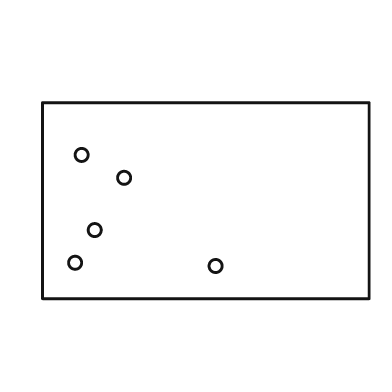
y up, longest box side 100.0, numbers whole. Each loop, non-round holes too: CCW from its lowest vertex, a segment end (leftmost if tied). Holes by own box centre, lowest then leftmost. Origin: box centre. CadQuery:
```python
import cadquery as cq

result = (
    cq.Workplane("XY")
    .moveTo(-50.0, -30.0)
    .lineTo(50.0, -30.0)
    .lineTo(50.0, 30.0)
    .lineTo(-50.0, 30.0)
    .close()
    .moveTo(3.0, -20.0)
    .circle(2.0)
    .moveTo(-40.0, -19.0)
    .circle(2.0)
    .moveTo(-34.0, -9.0)
    .circle(2.0)
    .moveTo(-25.0, 7.0)
    .circle(2.0)
    .moveTo(-38.0, 14.0)
    .circle(2.0)
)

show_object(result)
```